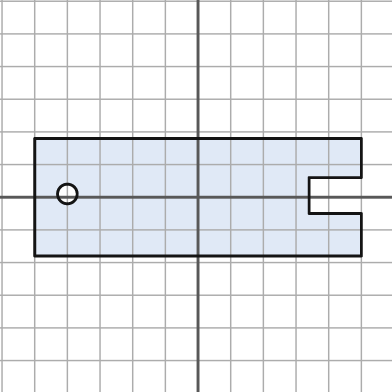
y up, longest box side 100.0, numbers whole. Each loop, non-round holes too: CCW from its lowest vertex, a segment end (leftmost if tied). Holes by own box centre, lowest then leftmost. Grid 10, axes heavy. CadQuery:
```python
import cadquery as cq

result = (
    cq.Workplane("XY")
    .moveTo(-50.0, -18.0)
    .lineTo(50.0, -18.0)
    .lineTo(50.0, -5.0)
    .lineTo(34.0, -5.0)
    .lineTo(34.0, 6.0)
    .lineTo(50.0, 6.0)
    .lineTo(50.0, 18.0)
    .lineTo(-50.0, 18.0)
    .close()
    .moveTo(-40.0, 1.0)
    .circle(3.0)
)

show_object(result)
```